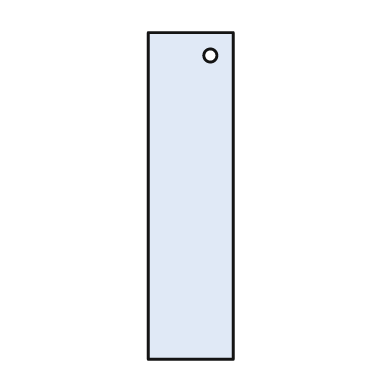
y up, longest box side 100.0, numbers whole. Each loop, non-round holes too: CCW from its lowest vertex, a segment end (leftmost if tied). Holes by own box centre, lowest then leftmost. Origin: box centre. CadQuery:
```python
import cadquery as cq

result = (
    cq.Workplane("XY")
    .moveTo(-13.0, -50.0)
    .lineTo(13.0, -50.0)
    .lineTo(13.0, 50.0)
    .lineTo(-13.0, 50.0)
    .close()
    .moveTo(6.0, 43.0)
    .circle(2.0)
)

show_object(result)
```